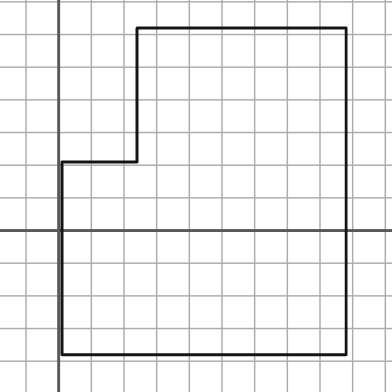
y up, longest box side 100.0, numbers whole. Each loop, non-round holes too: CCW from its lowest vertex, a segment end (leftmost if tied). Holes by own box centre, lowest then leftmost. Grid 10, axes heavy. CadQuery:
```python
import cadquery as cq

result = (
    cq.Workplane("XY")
    .moveTo(1.0, -38.0)
    .lineTo(88.0, -38.0)
    .lineTo(88.0, 62.0)
    .lineTo(24.0, 62.0)
    .lineTo(24.0, 21.0)
    .lineTo(1.0, 21.0)
    .close()
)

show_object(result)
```